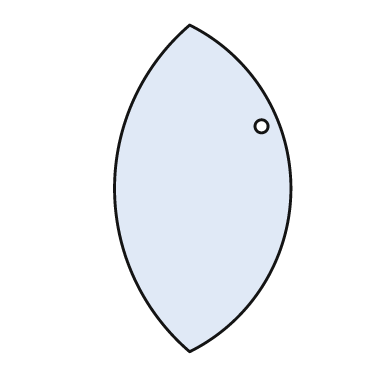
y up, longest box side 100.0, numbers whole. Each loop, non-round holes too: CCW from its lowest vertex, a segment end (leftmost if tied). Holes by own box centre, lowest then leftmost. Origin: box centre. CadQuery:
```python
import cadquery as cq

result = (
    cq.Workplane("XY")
    .moveTo(-4.0, -50.0)
    .threePointArc((27.0, 0.0), (-4.0, 50.0))
    .threePointArc((-27.0, 0.0), (-4.0, -50.0))
    .close()
    .moveTo(18.0, 19.0)
    .circle(2.0)
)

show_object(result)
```